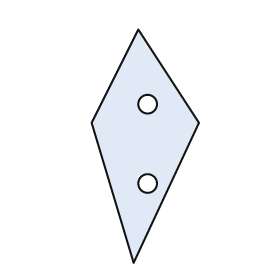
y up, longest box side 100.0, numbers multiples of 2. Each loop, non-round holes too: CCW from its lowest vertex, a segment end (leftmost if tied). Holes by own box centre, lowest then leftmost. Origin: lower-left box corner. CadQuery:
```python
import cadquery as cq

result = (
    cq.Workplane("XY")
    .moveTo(18.0, 0.0)
    .lineTo(46.0, 60.0)
    .lineTo(20.0, 100.0)
    .lineTo(0.0, 60.0)
    .close()
    .moveTo(24.0, 34.0)
    .circle(4.0)
    .moveTo(24.0, 68.0)
    .circle(4.0)
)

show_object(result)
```